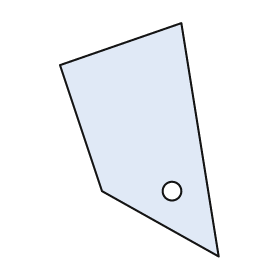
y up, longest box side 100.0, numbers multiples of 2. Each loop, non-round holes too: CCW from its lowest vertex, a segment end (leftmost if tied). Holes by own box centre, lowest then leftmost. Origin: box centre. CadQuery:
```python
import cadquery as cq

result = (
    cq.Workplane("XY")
    .moveTo(34.0, -50.0)
    .lineTo(18.0, 50.0)
    .lineTo(-34.0, 32.0)
    .lineTo(-16.0, -22.0)
    .close()
    .moveTo(14.0, -22.0)
    .circle(4.0)
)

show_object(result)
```